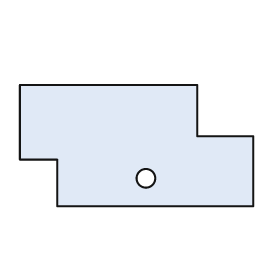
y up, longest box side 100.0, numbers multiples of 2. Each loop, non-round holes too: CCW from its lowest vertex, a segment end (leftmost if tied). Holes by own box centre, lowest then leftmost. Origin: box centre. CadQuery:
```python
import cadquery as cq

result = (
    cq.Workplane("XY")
    .moveTo(-34.0, -26.0)
    .lineTo(50.0, -26.0)
    .lineTo(50.0, 4.0)
    .lineTo(26.0, 4.0)
    .lineTo(26.0, 26.0)
    .lineTo(-50.0, 26.0)
    .lineTo(-50.0, -6.0)
    .lineTo(-34.0, -6.0)
    .close()
    .moveTo(4.0, -14.0)
    .circle(4.0)
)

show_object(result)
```